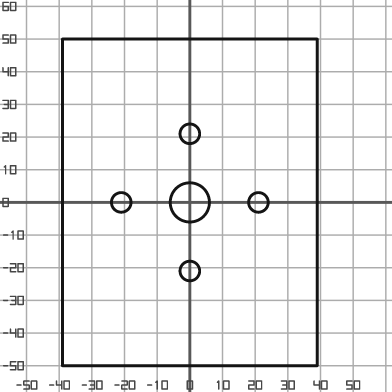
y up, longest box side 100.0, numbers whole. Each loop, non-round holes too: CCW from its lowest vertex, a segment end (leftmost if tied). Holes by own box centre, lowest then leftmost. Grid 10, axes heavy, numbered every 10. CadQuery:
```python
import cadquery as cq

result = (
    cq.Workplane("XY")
    .moveTo(-39.0, -50.0)
    .lineTo(39.0, -50.0)
    .lineTo(39.0, 50.0)
    .lineTo(-39.0, 50.0)
    .close()
    .moveTo(0.0, -21.0)
    .circle(3.0)
    .moveTo(-21.0, 0.0)
    .circle(3.0)
    .moveTo(0.0, 0.0)
    .circle(6.0)
    .moveTo(21.0, 0.0)
    .circle(3.0)
    .moveTo(0.0, 21.0)
    .circle(3.0)
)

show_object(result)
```